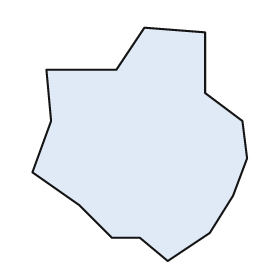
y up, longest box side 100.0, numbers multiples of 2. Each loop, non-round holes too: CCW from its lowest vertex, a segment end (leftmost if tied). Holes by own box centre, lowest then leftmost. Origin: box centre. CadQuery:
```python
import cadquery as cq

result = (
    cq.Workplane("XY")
    .moveTo(12.0, -50.0)
    .lineTo(30.0, -38.0)
    .lineTo(40.0, -22.0)
    .lineTo(46.0, -6.0)
    .lineTo(44.0, 10.0)
    .lineTo(28.0, 22.0)
    .lineTo(28.0, 48.0)
    .lineTo(2.0, 50.0)
    .lineTo(-10.0, 32.0)
    .lineTo(-40.0, 32.0)
    .lineTo(-38.0, 10.0)
    .lineTo(-46.0, -12.0)
    .lineTo(-26.0, -26.0)
    .lineTo(-12.0, -40.0)
    .lineTo(0.0, -40.0)
    .close()
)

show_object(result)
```